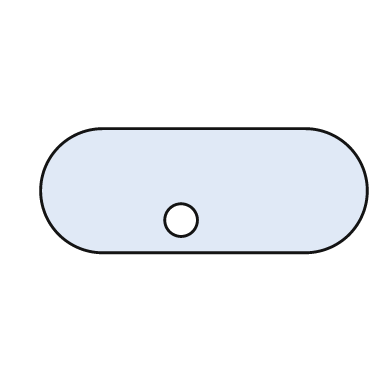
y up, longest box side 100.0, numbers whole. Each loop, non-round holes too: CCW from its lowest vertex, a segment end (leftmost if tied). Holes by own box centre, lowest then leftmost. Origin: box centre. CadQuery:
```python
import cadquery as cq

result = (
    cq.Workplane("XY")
    .moveTo(-31.0, -19.0)
    .lineTo(31.0, -19.0)
    .threePointArc((50.0, 0.0), (31.0, 19.0))
    .lineTo(-31.0, 19.0)
    .threePointArc((-50.0, 0.0), (-31.0, -19.0))
    .close()
    .moveTo(-7.0, -9.0)
    .circle(5.0)
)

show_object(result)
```